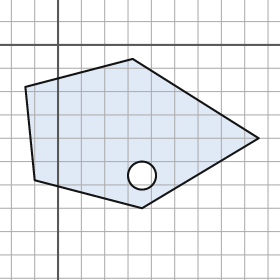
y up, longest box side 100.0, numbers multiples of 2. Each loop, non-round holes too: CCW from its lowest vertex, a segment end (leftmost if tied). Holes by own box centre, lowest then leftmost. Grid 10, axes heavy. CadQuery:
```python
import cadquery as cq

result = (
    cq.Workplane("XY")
    .moveTo(36.0, -70.0)
    .lineTo(86.0, -40.0)
    .lineTo(32.0, -6.0)
    .lineTo(-14.0, -18.0)
    .lineTo(-10.0, -58.0)
    .close()
    .moveTo(36.0, -56.0)
    .circle(6.0)
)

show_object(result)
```